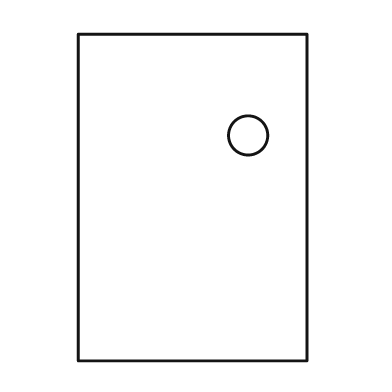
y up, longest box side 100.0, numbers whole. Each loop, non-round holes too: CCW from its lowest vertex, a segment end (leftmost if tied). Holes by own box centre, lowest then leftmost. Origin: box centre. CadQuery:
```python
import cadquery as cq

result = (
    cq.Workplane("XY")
    .moveTo(-35.0, -50.0)
    .lineTo(35.0, -50.0)
    .lineTo(35.0, 50.0)
    .lineTo(-35.0, 50.0)
    .close()
    .moveTo(17.0, 19.0)
    .circle(6.0)
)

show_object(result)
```